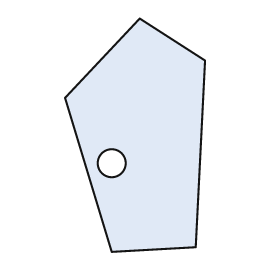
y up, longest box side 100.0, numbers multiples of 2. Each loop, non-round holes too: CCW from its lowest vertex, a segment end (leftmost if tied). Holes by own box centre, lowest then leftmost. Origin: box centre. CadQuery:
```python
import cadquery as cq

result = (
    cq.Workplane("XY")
    .moveTo(-10.0, -50.0)
    .lineTo(26.0, -48.0)
    .lineTo(30.0, 32.0)
    .lineTo(2.0, 50.0)
    .lineTo(-30.0, 16.0)
    .close()
    .moveTo(-10.0, -12.0)
    .circle(6.0)
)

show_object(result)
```